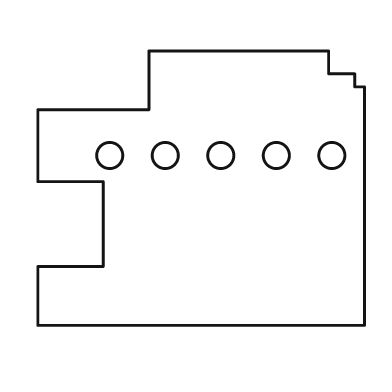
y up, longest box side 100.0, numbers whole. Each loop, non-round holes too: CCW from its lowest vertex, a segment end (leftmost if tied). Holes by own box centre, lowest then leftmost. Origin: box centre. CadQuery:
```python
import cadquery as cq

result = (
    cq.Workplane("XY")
    .moveTo(-50.0, -42.0)
    .lineTo(50.0, -42.0)
    .lineTo(50.0, 31.0)
    .lineTo(47.0, 31.0)
    .lineTo(47.0, 35.0)
    .lineTo(39.0, 35.0)
    .lineTo(39.0, 42.0)
    .lineTo(-16.0, 42.0)
    .lineTo(-16.0, 24.0)
    .lineTo(-50.0, 24.0)
    .lineTo(-50.0, 2.0)
    .lineTo(-30.0, 2.0)
    .lineTo(-30.0, -24.0)
    .lineTo(-50.0, -24.0)
    .close()
    .moveTo(-28.0, 10.0)
    .circle(4.0)
    .moveTo(-11.0, 10.0)
    .circle(4.0)
    .moveTo(6.0, 10.0)
    .circle(4.0)
    .moveTo(23.0, 10.0)
    .circle(4.0)
    .moveTo(40.0, 10.0)
    .circle(4.0)
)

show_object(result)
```